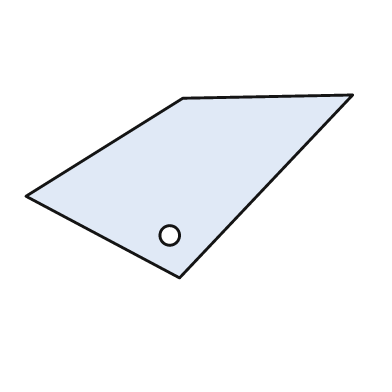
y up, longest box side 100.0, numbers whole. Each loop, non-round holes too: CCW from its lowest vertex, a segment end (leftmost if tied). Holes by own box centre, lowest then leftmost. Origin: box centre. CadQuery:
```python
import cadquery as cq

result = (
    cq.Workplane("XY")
    .moveTo(-3.0, -28.0)
    .lineTo(50.0, 28.0)
    .lineTo(-2.0, 27.0)
    .lineTo(-50.0, -3.0)
    .close()
    .moveTo(-6.0, -15.0)
    .circle(3.0)
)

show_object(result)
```